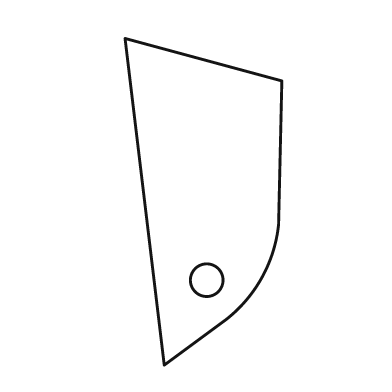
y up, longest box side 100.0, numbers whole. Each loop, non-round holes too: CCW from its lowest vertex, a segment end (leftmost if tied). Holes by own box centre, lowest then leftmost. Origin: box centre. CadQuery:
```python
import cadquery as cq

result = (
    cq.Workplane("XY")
    .moveTo(-12.0, -50.0)
    .lineTo(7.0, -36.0)
    .threePointArc((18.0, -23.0), (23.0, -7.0))
    .lineTo(24.0, 37.0)
    .lineTo(-24.0, 50.0)
    .close()
    .moveTo(1.0, -24.0)
    .circle(5.0)
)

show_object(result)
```